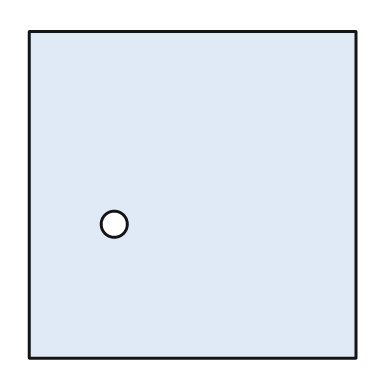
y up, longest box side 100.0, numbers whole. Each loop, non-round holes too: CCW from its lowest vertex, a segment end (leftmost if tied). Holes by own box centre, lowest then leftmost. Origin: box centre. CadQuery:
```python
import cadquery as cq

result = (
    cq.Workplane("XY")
    .moveTo(-50.0, -50.0)
    .lineTo(50.0, -50.0)
    .lineTo(50.0, 50.0)
    .lineTo(-50.0, 50.0)
    .close()
    .moveTo(-24.0, -9.0)
    .circle(4.0)
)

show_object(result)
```